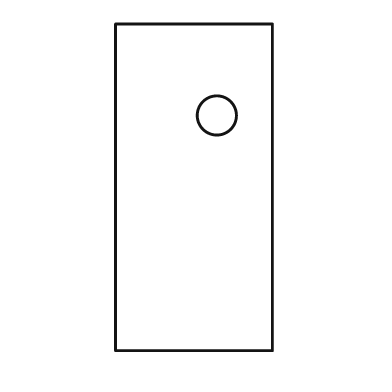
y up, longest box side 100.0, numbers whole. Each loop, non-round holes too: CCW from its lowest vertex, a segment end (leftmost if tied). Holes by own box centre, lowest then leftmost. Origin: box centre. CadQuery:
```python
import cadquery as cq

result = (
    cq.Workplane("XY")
    .moveTo(-24.0, -50.0)
    .lineTo(24.0, -50.0)
    .lineTo(24.0, 50.0)
    .lineTo(-24.0, 50.0)
    .close()
    .moveTo(7.0, 22.0)
    .circle(6.0)
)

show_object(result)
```